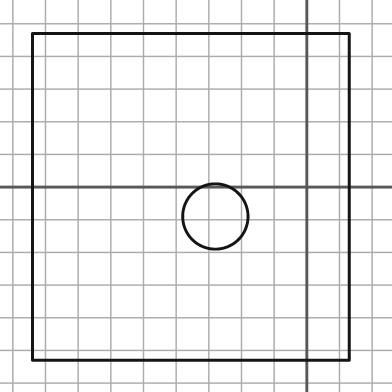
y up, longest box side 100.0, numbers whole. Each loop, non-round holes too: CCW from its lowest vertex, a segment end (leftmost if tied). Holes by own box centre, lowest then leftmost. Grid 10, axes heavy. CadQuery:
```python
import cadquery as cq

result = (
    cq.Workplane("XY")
    .moveTo(-84.0, -53.0)
    .lineTo(13.0, -53.0)
    .lineTo(13.0, 47.0)
    .lineTo(-84.0, 47.0)
    .close()
    .moveTo(-28.0, -9.0)
    .circle(10.0)
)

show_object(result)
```